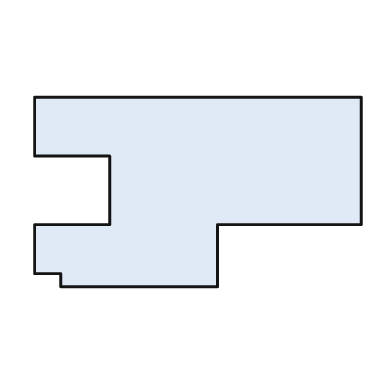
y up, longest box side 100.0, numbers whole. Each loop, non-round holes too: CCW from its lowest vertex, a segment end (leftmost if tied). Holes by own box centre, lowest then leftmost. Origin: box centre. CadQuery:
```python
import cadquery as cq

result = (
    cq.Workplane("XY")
    .moveTo(-42.0, -29.0)
    .lineTo(6.0, -29.0)
    .lineTo(6.0, -10.0)
    .lineTo(50.0, -10.0)
    .lineTo(50.0, 29.0)
    .lineTo(-50.0, 29.0)
    .lineTo(-50.0, 11.0)
    .lineTo(-27.0, 11.0)
    .lineTo(-27.0, -10.0)
    .lineTo(-50.0, -10.0)
    .lineTo(-50.0, -25.0)
    .lineTo(-42.0, -25.0)
    .close()
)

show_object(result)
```